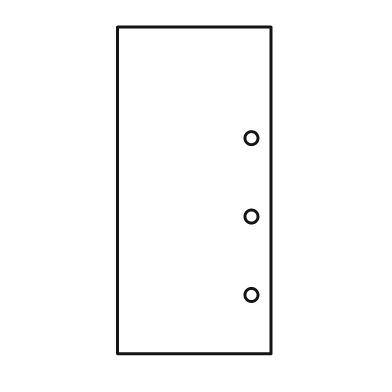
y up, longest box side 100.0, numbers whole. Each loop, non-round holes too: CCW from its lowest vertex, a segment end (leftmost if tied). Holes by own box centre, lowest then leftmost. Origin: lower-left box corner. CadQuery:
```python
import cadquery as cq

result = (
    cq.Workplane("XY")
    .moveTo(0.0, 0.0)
    .lineTo(47.0, 0.0)
    .lineTo(47.0, 100.0)
    .lineTo(0.0, 100.0)
    .close()
    .moveTo(41.0, 18.0)
    .circle(2.0)
    .moveTo(41.0, 42.0)
    .circle(2.0)
    .moveTo(41.0, 66.0)
    .circle(2.0)
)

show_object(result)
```